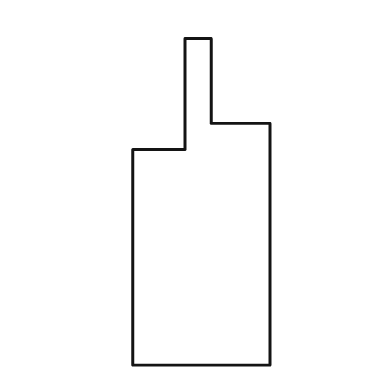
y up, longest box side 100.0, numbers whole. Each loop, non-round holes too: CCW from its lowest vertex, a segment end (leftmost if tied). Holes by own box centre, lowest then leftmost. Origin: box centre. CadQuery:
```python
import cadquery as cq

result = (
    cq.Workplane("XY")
    .moveTo(-21.0, -50.0)
    .lineTo(21.0, -50.0)
    .lineTo(21.0, 24.0)
    .lineTo(3.0, 24.0)
    .lineTo(3.0, 50.0)
    .lineTo(-5.0, 50.0)
    .lineTo(-5.0, 16.0)
    .lineTo(-21.0, 16.0)
    .close()
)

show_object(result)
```